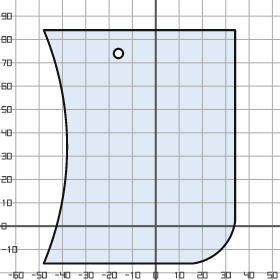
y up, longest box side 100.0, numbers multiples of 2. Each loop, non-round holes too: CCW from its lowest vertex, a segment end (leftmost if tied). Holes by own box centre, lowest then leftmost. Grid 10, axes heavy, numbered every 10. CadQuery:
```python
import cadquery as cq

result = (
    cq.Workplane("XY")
    .moveTo(-48.0, -16.0)
    .lineTo(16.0, -16.0)
    .threePointArc((28.0, -10.0), (34.0, 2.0))
    .lineTo(34.0, 84.0)
    .lineTo(-48.0, 84.0)
    .threePointArc((-38.0, 34.0), (-48.0, -16.0))
    .close()
    .moveTo(-16.0, 74.0)
    .circle(2.0)
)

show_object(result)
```